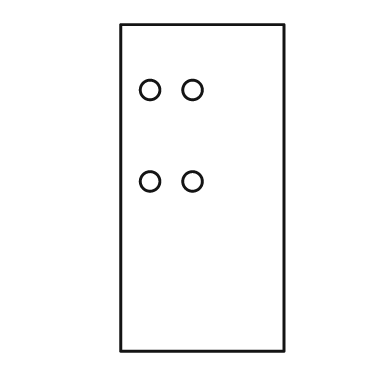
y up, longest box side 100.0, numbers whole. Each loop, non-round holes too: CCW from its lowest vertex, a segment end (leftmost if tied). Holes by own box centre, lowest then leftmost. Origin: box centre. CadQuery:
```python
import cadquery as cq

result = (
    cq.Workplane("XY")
    .moveTo(-25.0, -50.0)
    .lineTo(25.0, -50.0)
    .lineTo(25.0, 50.0)
    .lineTo(-25.0, 50.0)
    .close()
    .moveTo(-16.0, 2.0)
    .circle(3.0)
    .moveTo(-3.0, 2.0)
    .circle(3.0)
    .moveTo(-16.0, 30.0)
    .circle(3.0)
    .moveTo(-3.0, 30.0)
    .circle(3.0)
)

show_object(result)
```